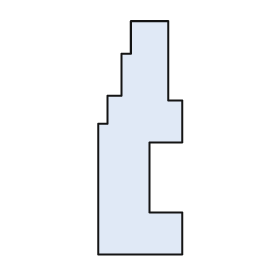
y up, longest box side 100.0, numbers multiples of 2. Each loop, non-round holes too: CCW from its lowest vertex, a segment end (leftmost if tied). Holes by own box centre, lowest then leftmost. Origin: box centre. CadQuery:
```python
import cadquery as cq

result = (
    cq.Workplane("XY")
    .moveTo(-18.0, -50.0)
    .lineTo(18.0, -50.0)
    .lineTo(18.0, -32.0)
    .lineTo(4.0, -32.0)
    .lineTo(4.0, -2.0)
    .lineTo(18.0, -2.0)
    .lineTo(18.0, 16.0)
    .lineTo(12.0, 16.0)
    .lineTo(12.0, 50.0)
    .lineTo(-4.0, 50.0)
    .lineTo(-4.0, 36.0)
    .lineTo(-8.0, 36.0)
    .lineTo(-8.0, 18.0)
    .lineTo(-14.0, 18.0)
    .lineTo(-14.0, 6.0)
    .lineTo(-18.0, 6.0)
    .close()
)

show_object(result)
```